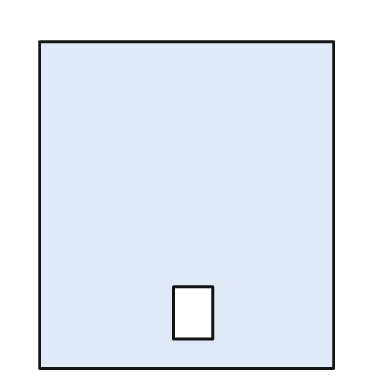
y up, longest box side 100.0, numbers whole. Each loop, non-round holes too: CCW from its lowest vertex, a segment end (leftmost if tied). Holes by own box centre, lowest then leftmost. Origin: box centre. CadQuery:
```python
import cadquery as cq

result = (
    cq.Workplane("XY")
    .moveTo(-45.0, -50.0)
    .lineTo(45.0, -50.0)
    .lineTo(45.0, 50.0)
    .lineTo(-45.0, 50.0)
    .close()
    .moveTo(-4.0, -41.0)
    .lineTo(8.0, -41.0)
    .lineTo(8.0, -25.0)
    .lineTo(-4.0, -25.0)
    .close()
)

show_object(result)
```